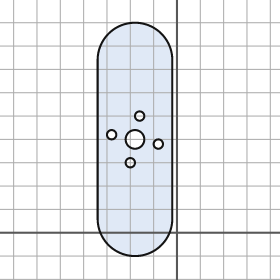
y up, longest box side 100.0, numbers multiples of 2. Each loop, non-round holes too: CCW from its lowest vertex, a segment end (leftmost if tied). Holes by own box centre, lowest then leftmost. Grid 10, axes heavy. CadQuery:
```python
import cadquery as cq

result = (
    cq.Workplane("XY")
    .moveTo(-34.0, 6.0)
    .threePointArc((-18.0, -10.0), (-2.0, 6.0))
    .lineTo(-2.0, 74.0)
    .threePointArc((-18.0, 90.0), (-34.0, 74.0))
    .close()
    .moveTo(-20.0, 30.0)
    .circle(2.0)
    .moveTo(-8.0, 38.0)
    .circle(2.0)
    .moveTo(-18.0, 40.0)
    .circle(4.0)
    .moveTo(-28.0, 42.0)
    .circle(2.0)
    .moveTo(-16.0, 50.0)
    .circle(2.0)
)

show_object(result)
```